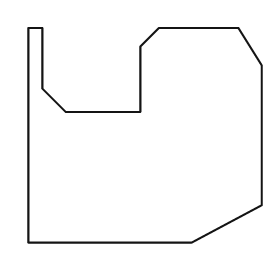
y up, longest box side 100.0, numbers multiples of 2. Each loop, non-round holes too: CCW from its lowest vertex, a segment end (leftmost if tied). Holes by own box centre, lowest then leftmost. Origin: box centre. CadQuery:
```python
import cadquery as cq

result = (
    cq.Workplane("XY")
    .moveTo(-50.0, -46.0)
    .lineTo(20.0, -46.0)
    .lineTo(50.0, -30.0)
    .lineTo(50.0, 30.0)
    .lineTo(40.0, 46.0)
    .lineTo(6.0, 46.0)
    .lineTo(-2.0, 38.0)
    .lineTo(-2.0, 10.0)
    .lineTo(-34.0, 10.0)
    .lineTo(-44.0, 20.0)
    .lineTo(-44.0, 46.0)
    .lineTo(-50.0, 46.0)
    .close()
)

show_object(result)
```